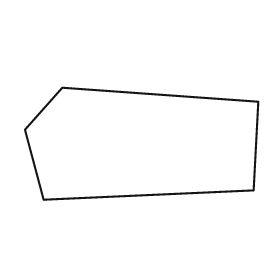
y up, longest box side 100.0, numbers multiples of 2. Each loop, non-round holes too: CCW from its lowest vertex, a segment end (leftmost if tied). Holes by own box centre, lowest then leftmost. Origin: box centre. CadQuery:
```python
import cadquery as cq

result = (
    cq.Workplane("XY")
    .moveTo(-42.0, -24.0)
    .lineTo(48.0, -20.0)
    .lineTo(50.0, 18.0)
    .lineTo(-34.0, 24.0)
    .lineTo(-50.0, 6.0)
    .close()
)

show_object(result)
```